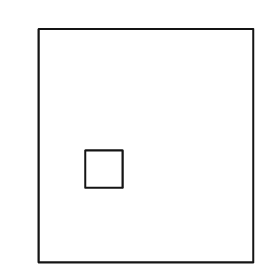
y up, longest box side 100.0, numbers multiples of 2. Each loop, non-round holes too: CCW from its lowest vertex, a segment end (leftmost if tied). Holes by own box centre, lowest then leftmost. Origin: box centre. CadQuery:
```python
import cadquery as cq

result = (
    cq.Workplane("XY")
    .moveTo(-46.0, -50.0)
    .lineTo(46.0, -50.0)
    .lineTo(46.0, 50.0)
    .lineTo(-46.0, 50.0)
    .close()
    .moveTo(-26.0, -18.0)
    .lineTo(-10.0, -18.0)
    .lineTo(-10.0, -2.0)
    .lineTo(-26.0, -2.0)
    .close()
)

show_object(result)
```